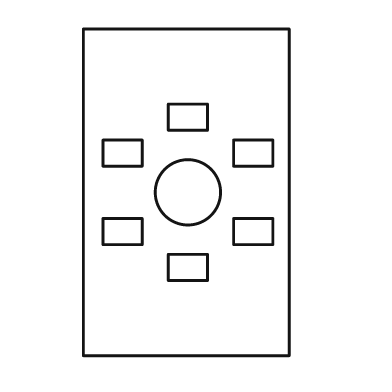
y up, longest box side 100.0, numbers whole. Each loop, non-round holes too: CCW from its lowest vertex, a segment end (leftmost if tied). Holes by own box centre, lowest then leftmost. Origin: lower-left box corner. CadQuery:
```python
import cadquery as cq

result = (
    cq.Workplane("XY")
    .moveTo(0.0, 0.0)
    .lineTo(63.0, 0.0)
    .lineTo(63.0, 100.0)
    .lineTo(0.0, 100.0)
    .close()
    .moveTo(26.0, 23.0)
    .lineTo(38.0, 23.0)
    .lineTo(38.0, 31.0)
    .lineTo(26.0, 31.0)
    .close()
    .moveTo(6.0, 34.0)
    .lineTo(18.0, 34.0)
    .lineTo(18.0, 42.0)
    .lineTo(6.0, 42.0)
    .close()
    .moveTo(46.0, 34.0)
    .lineTo(58.0, 34.0)
    .lineTo(58.0, 42.0)
    .lineTo(46.0, 42.0)
    .close()
    .moveTo(32.0, 50.0)
    .circle(10.0)
    .moveTo(6.0, 58.0)
    .lineTo(18.0, 58.0)
    .lineTo(18.0, 66.0)
    .lineTo(6.0, 66.0)
    .close()
    .moveTo(46.0, 58.0)
    .lineTo(58.0, 58.0)
    .lineTo(58.0, 66.0)
    .lineTo(46.0, 66.0)
    .close()
    .moveTo(26.0, 69.0)
    .lineTo(38.0, 69.0)
    .lineTo(38.0, 77.0)
    .lineTo(26.0, 77.0)
    .close()
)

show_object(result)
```